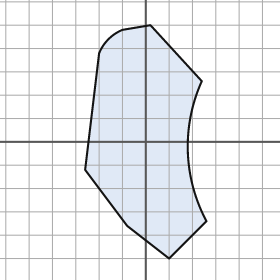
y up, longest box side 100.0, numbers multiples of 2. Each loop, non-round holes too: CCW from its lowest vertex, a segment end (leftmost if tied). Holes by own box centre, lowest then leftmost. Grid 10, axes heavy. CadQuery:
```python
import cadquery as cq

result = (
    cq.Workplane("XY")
    .moveTo(10.0, -50.0)
    .lineTo(26.0, -34.0)
    .threePointArc((18.0, -4.0), (24.0, 26.0))
    .lineTo(2.0, 50.0)
    .lineTo(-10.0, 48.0)
    .threePointArc((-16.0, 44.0), (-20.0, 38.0))
    .lineTo(-26.0, -12.0)
    .lineTo(-8.0, -36.0)
    .close()
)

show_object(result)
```